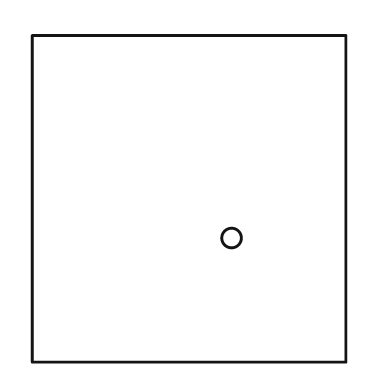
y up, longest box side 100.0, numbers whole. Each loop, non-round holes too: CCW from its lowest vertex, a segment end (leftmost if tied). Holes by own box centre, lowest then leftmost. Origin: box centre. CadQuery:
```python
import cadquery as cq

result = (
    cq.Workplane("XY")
    .moveTo(-48.0, -50.0)
    .lineTo(48.0, -50.0)
    .lineTo(48.0, 50.0)
    .lineTo(-48.0, 50.0)
    .close()
    .moveTo(13.0, -12.0)
    .circle(3.0)
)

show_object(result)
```